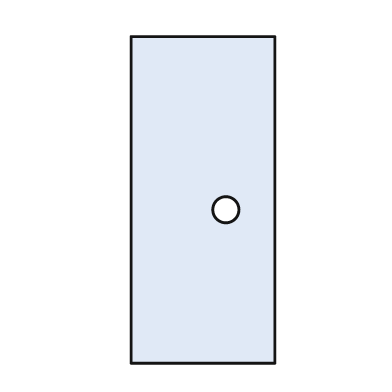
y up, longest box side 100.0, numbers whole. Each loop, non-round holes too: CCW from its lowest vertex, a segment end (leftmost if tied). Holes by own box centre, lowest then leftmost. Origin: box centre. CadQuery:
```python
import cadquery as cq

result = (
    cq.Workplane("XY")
    .moveTo(-22.0, -50.0)
    .lineTo(22.0, -50.0)
    .lineTo(22.0, 50.0)
    .lineTo(-22.0, 50.0)
    .close()
    .moveTo(7.0, -3.0)
    .circle(4.0)
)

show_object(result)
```